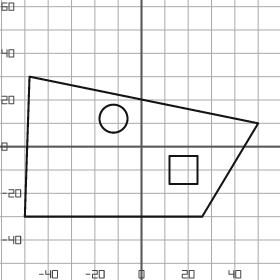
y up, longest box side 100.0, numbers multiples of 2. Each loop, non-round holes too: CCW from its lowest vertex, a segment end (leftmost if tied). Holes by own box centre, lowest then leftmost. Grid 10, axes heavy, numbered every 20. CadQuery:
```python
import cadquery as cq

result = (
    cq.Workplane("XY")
    .moveTo(-50.0, -30.0)
    .lineTo(26.0, -30.0)
    .lineTo(50.0, 10.0)
    .lineTo(-48.0, 30.0)
    .close()
    .moveTo(12.0, -16.0)
    .lineTo(24.0, -16.0)
    .lineTo(24.0, -4.0)
    .lineTo(12.0, -4.0)
    .close()
    .moveTo(-12.0, 12.0)
    .circle(6.0)
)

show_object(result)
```